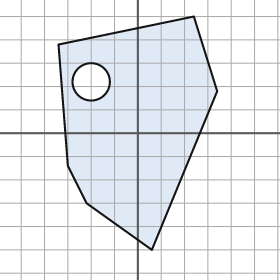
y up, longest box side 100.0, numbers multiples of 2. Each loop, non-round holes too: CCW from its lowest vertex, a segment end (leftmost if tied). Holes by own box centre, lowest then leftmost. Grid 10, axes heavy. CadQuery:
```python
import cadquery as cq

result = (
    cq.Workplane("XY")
    .moveTo(6.0, -50.0)
    .lineTo(34.0, 18.0)
    .lineTo(24.0, 50.0)
    .lineTo(-34.0, 38.0)
    .lineTo(-30.0, -14.0)
    .lineTo(-22.0, -30.0)
    .close()
    .moveTo(-20.0, 22.0)
    .circle(8.0)
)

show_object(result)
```